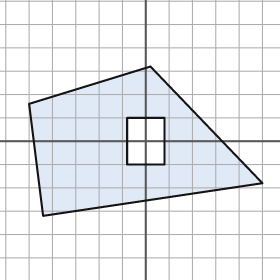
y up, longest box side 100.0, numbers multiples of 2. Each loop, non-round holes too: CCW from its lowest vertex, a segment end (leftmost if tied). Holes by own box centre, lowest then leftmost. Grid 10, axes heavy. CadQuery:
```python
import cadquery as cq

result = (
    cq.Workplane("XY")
    .moveTo(-44.0, -32.0)
    .lineTo(50.0, -18.0)
    .lineTo(2.0, 32.0)
    .lineTo(-50.0, 16.0)
    .close()
    .moveTo(-8.0, -10.0)
    .lineTo(8.0, -10.0)
    .lineTo(8.0, 10.0)
    .lineTo(-8.0, 10.0)
    .close()
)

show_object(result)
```